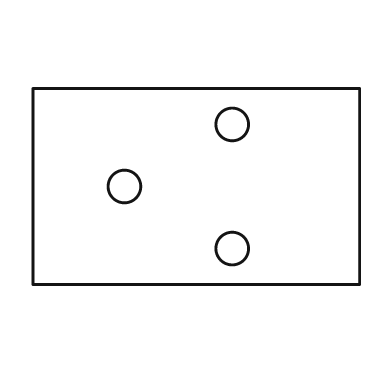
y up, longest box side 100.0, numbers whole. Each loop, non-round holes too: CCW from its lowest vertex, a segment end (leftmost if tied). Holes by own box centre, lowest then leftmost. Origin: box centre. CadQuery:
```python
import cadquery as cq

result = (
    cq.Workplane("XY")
    .moveTo(-50.0, -30.0)
    .lineTo(50.0, -30.0)
    .lineTo(50.0, 30.0)
    .lineTo(-50.0, 30.0)
    .close()
    .moveTo(11.0, -19.0)
    .circle(5.0)
    .moveTo(-22.0, 0.0)
    .circle(5.0)
    .moveTo(11.0, 19.0)
    .circle(5.0)
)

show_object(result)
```